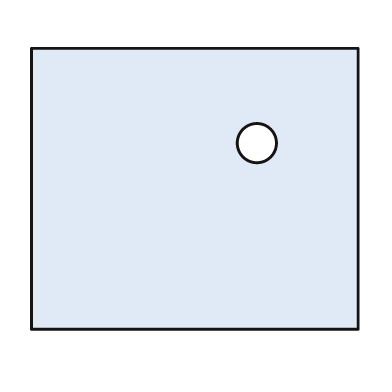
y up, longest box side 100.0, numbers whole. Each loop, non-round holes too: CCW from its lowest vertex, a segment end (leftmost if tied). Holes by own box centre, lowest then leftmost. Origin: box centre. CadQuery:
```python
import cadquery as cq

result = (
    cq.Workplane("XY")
    .moveTo(-50.0, -43.0)
    .lineTo(50.0, -43.0)
    .lineTo(50.0, 43.0)
    .lineTo(-50.0, 43.0)
    .close()
    .moveTo(19.0, 14.0)
    .circle(6.0)
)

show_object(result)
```